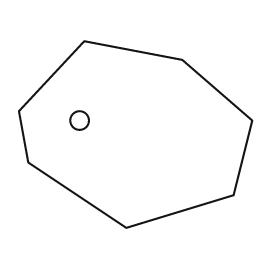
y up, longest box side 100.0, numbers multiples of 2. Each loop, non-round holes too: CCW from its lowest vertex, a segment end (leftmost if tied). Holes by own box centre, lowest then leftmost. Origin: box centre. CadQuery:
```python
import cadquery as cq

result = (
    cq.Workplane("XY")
    .moveTo(-4.0, -40.0)
    .lineTo(42.0, -26.0)
    .lineTo(50.0, 6.0)
    .lineTo(20.0, 32.0)
    .lineTo(-22.0, 40.0)
    .lineTo(-50.0, 10.0)
    .lineTo(-46.0, -12.0)
    .close()
    .moveTo(-24.0, 6.0)
    .circle(4.0)
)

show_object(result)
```